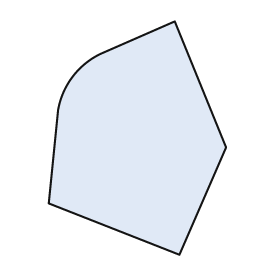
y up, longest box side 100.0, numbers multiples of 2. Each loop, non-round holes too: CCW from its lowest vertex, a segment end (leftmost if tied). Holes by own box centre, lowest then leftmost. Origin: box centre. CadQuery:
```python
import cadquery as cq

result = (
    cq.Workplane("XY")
    .moveTo(18.0, -50.0)
    .lineTo(38.0, -4.0)
    .lineTo(16.0, 50.0)
    .lineTo(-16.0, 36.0)
    .threePointArc((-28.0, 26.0), (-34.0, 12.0))
    .lineTo(-38.0, -28.0)
    .close()
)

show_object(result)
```